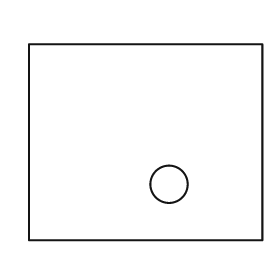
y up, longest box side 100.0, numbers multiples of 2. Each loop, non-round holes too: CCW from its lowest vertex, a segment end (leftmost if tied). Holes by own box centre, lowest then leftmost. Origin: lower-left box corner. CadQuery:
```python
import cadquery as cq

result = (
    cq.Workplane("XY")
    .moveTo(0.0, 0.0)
    .lineTo(100.0, 0.0)
    .lineTo(100.0, 84.0)
    .lineTo(0.0, 84.0)
    .close()
    .moveTo(60.0, 24.0)
    .circle(8.0)
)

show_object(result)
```